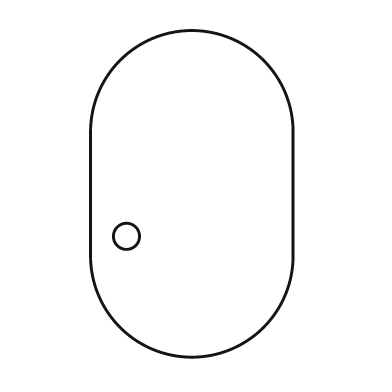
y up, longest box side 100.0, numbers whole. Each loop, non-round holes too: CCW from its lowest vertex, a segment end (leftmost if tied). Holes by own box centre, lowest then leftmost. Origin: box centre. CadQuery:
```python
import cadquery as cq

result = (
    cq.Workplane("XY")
    .moveTo(-31.0, -19.0)
    .threePointArc((0.0, -50.0), (31.0, -19.0))
    .lineTo(31.0, 19.0)
    .threePointArc((0.0, 50.0), (-31.0, 19.0))
    .close()
    .moveTo(-20.0, -13.0)
    .circle(4.0)
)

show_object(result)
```